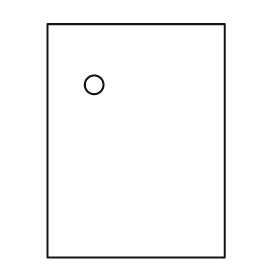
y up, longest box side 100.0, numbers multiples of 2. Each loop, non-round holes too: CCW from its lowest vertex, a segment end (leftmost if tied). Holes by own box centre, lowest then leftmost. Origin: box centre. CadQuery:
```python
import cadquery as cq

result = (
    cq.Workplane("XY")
    .moveTo(-38.0, -50.0)
    .lineTo(38.0, -50.0)
    .lineTo(38.0, 50.0)
    .lineTo(-38.0, 50.0)
    .close()
    .moveTo(-18.0, 24.0)
    .circle(4.0)
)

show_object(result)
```